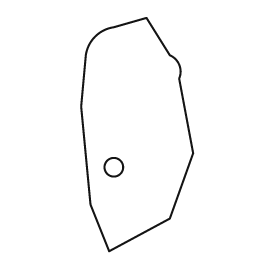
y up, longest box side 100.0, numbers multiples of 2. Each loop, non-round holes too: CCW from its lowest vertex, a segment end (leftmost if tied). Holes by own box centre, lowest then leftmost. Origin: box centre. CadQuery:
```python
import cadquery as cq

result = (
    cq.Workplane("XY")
    .moveTo(-12.0, -50.0)
    .lineTo(14.0, -36.0)
    .lineTo(24.0, -8.0)
    .lineTo(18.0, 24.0)
    .threePointArc((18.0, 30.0), (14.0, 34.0))
    .lineTo(4.0, 50.0)
    .lineTo(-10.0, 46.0)
    .threePointArc((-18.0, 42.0), (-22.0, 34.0))
    .lineTo(-24.0, 12.0)
    .lineTo(-20.0, -30.0)
    .close()
    .moveTo(-10.0, -14.0)
    .circle(4.0)
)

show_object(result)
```